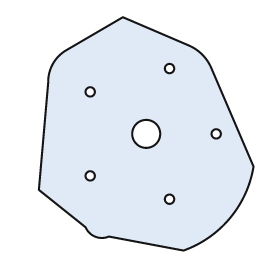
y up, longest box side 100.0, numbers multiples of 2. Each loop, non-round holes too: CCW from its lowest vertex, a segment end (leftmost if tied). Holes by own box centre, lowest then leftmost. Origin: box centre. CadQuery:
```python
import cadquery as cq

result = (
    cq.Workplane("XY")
    .moveTo(16.0, -50.0)
    .threePointArc((36.0, -36.0), (46.0, -14.0))
    .lineTo(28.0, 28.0)
    .threePointArc((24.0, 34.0), (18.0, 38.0))
    .lineTo(-10.0, 50.0)
    .lineTo(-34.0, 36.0)
    .threePointArc((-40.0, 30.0), (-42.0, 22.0))
    .lineTo(-46.0, -24.0)
    .lineTo(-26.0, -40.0)
    .threePointArc((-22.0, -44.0), (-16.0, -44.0))
    .close()
    .moveTo(10.0, -28.0)
    .circle(2.0)
    .moveTo(-24.0, -18.0)
    .circle(2.0)
    .moveTo(0.0, 0.0)
    .circle(6.0)
    .moveTo(30.0, 0.0)
    .circle(2.0)
    .moveTo(-24.0, 18.0)
    .circle(2.0)
    .moveTo(10.0, 28.0)
    .circle(2.0)
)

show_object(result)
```